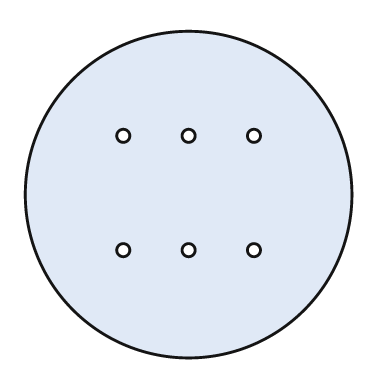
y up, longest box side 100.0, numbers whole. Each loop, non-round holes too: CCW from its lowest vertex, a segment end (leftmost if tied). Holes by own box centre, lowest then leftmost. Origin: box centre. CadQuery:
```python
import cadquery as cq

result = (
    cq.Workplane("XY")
    .moveTo(0.0, 0.0)
    .circle(50.0)
    .moveTo(-20.0, -17.0)
    .circle(2.0)
    .moveTo(0.0, -17.0)
    .circle(2.0)
    .moveTo(20.0, -17.0)
    .circle(2.0)
    .moveTo(-20.0, 18.0)
    .circle(2.0)
    .moveTo(0.0, 18.0)
    .circle(2.0)
    .moveTo(20.0, 18.0)
    .circle(2.0)
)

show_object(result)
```